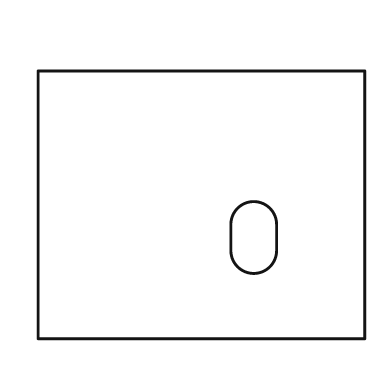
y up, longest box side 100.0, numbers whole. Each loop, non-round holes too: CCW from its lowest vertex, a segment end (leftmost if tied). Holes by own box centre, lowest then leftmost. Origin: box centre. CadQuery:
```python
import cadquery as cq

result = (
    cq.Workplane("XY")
    .moveTo(-50.0, -41.0)
    .lineTo(50.0, -41.0)
    .lineTo(50.0, 41.0)
    .lineTo(-50.0, 41.0)
    .close()
    .moveTo(9.0, -14.0)
    .threePointArc((16.0, -21.0), (23.0, -14.0))
    .lineTo(23.0, -6.0)
    .threePointArc((16.0, 1.0), (9.0, -6.0))
    .close()
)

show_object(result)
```